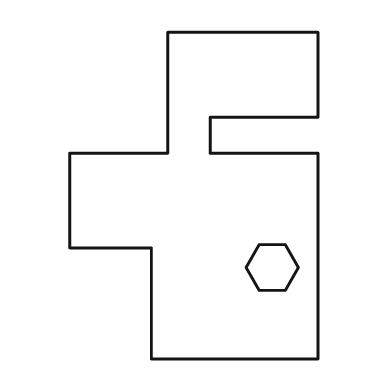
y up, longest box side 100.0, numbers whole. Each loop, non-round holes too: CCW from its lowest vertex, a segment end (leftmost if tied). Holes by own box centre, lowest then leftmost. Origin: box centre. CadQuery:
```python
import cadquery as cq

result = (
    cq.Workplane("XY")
    .moveTo(-13.0, -50.0)
    .lineTo(38.0, -50.0)
    .lineTo(38.0, 13.0)
    .lineTo(5.0, 13.0)
    .lineTo(5.0, 24.0)
    .lineTo(38.0, 24.0)
    .lineTo(38.0, 50.0)
    .lineTo(-8.0, 50.0)
    .lineTo(-8.0, 13.0)
    .lineTo(-38.0, 13.0)
    .lineTo(-38.0, -16.0)
    .lineTo(-13.0, -16.0)
    .close()
    .moveTo(20.0, -29.0)
    .lineTo(28.0, -29.0)
    .lineTo(32.0, -22.0)
    .lineTo(28.0, -15.0)
    .lineTo(20.0, -15.0)
    .lineTo(16.0, -22.0)
    .close()
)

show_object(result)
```